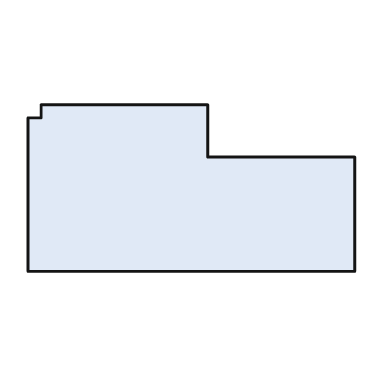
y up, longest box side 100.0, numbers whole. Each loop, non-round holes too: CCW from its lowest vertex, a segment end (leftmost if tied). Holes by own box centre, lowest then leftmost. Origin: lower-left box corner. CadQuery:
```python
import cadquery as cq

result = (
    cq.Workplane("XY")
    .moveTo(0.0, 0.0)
    .lineTo(100.0, 0.0)
    .lineTo(100.0, 35.0)
    .lineTo(55.0, 35.0)
    .lineTo(55.0, 51.0)
    .lineTo(4.0, 51.0)
    .lineTo(4.0, 47.0)
    .lineTo(0.0, 47.0)
    .close()
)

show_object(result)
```